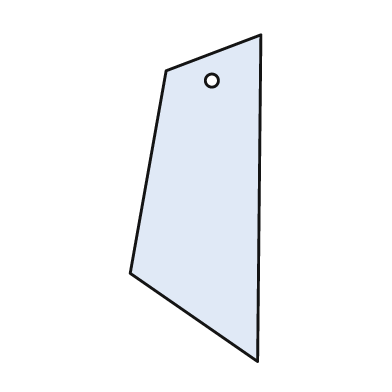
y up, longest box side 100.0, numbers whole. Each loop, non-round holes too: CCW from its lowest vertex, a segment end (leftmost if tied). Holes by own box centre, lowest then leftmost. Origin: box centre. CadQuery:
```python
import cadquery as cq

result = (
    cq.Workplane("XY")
    .moveTo(19.0, -50.0)
    .lineTo(20.0, 50.0)
    .lineTo(-9.0, 39.0)
    .lineTo(-20.0, -23.0)
    .close()
    .moveTo(5.0, 36.0)
    .circle(2.0)
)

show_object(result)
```